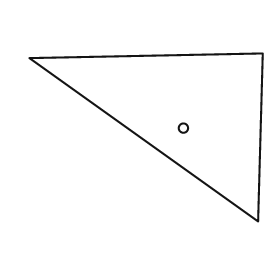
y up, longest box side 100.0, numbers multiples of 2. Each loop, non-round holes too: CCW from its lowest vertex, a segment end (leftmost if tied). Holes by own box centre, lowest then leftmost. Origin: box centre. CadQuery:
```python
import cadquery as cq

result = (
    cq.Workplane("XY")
    .moveTo(48.0, -36.0)
    .lineTo(50.0, 36.0)
    .lineTo(-50.0, 34.0)
    .close()
    .moveTo(16.0, 4.0)
    .circle(2.0)
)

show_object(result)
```